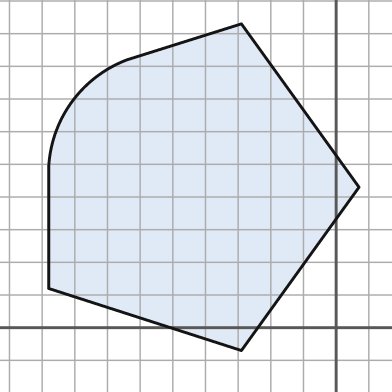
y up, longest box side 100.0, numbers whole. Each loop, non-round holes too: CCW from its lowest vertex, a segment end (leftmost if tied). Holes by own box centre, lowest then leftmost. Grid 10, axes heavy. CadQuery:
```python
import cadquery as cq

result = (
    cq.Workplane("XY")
    .moveTo(-29.0, -7.0)
    .lineTo(7.0, 43.0)
    .lineTo(-29.0, 93.0)
    .lineTo(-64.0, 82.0)
    .threePointArc((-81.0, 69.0), (-88.0, 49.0))
    .lineTo(-88.0, 12.0)
    .close()
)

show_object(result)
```